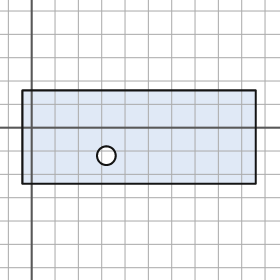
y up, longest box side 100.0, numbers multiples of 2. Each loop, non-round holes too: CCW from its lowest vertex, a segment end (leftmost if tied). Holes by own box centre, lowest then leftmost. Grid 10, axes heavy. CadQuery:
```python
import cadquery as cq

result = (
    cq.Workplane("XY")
    .moveTo(-4.0, -24.0)
    .lineTo(96.0, -24.0)
    .lineTo(96.0, 16.0)
    .lineTo(-4.0, 16.0)
    .close()
    .moveTo(32.0, -12.0)
    .circle(4.0)
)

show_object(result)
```